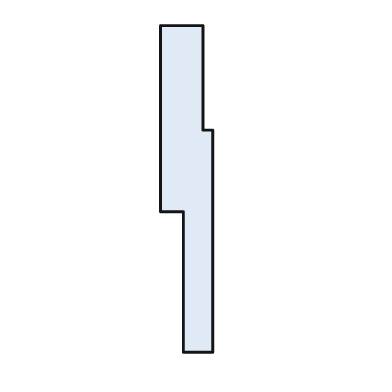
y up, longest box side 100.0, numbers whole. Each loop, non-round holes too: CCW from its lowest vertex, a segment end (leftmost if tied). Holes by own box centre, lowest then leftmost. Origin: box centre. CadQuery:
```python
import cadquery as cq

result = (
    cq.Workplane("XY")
    .moveTo(-1.0, -50.0)
    .lineTo(8.0, -50.0)
    .lineTo(8.0, 18.0)
    .lineTo(5.0, 18.0)
    .lineTo(5.0, 50.0)
    .lineTo(-8.0, 50.0)
    .lineTo(-8.0, -7.0)
    .lineTo(-1.0, -7.0)
    .close()
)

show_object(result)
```